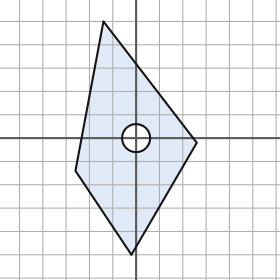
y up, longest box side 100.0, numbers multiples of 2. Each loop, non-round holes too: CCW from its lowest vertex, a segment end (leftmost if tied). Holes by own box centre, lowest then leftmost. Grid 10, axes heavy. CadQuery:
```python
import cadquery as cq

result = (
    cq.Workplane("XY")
    .moveTo(-2.0, -50.0)
    .lineTo(26.0, -2.0)
    .lineTo(-14.0, 50.0)
    .lineTo(-26.0, -14.0)
    .close()
    .moveTo(0.0, 0.0)
    .circle(6.0)
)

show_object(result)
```